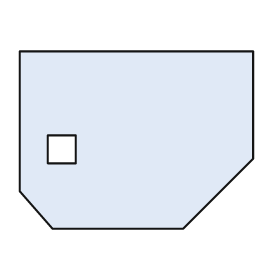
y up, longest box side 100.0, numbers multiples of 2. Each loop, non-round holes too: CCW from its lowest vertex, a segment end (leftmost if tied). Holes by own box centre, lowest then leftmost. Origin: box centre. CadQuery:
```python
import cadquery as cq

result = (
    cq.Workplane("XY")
    .moveTo(-36.0, -38.0)
    .lineTo(20.0, -38.0)
    .lineTo(50.0, -8.0)
    .lineTo(50.0, 38.0)
    .lineTo(-50.0, 38.0)
    .lineTo(-50.0, -22.0)
    .close()
    .moveTo(-38.0, -10.0)
    .lineTo(-26.0, -10.0)
    .lineTo(-26.0, 2.0)
    .lineTo(-38.0, 2.0)
    .close()
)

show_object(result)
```